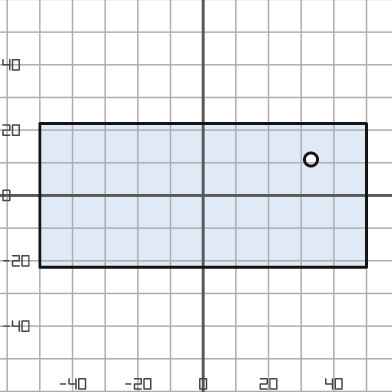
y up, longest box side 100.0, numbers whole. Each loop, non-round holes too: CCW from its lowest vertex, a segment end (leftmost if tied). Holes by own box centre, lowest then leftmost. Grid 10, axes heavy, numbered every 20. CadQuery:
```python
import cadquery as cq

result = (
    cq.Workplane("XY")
    .moveTo(-50.0, -22.0)
    .lineTo(50.0, -22.0)
    .lineTo(50.0, 22.0)
    .lineTo(-50.0, 22.0)
    .close()
    .moveTo(33.0, 11.0)
    .circle(2.0)
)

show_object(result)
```